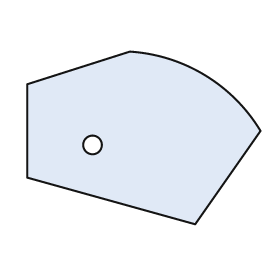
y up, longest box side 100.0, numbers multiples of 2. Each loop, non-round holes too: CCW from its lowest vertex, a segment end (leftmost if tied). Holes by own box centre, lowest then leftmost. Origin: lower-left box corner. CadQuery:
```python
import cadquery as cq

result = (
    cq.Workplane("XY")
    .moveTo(72.0, 0.0)
    .lineTo(100.0, 40.0)
    .threePointArc((76.0, 64.0), (44.0, 74.0))
    .lineTo(0.0, 60.0)
    .lineTo(0.0, 20.0)
    .close()
    .moveTo(28.0, 34.0)
    .circle(4.0)
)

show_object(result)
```